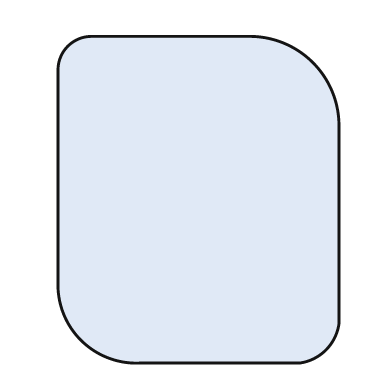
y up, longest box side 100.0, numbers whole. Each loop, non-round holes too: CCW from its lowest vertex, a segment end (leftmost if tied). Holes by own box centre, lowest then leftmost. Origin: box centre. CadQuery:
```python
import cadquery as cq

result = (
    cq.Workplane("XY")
    .moveTo(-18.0, -50.0)
    .lineTo(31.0, -50.0)
    .threePointArc((39.0, -46.0), (43.0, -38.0))
    .lineTo(43.0, 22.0)
    .threePointArc((35.0, 42.0), (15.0, 50.0))
    .lineTo(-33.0, 50.0)
    .threePointArc((-40.0, 47.0), (-43.0, 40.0))
    .lineTo(-43.0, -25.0)
    .threePointArc((-36.0, -43.0), (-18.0, -50.0))
    .close()
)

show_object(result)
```